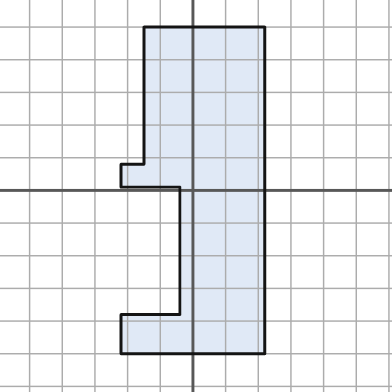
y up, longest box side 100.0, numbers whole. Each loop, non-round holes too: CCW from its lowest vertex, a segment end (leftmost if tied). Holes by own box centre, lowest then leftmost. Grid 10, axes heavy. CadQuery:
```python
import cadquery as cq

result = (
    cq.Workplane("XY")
    .moveTo(-22.0, -50.0)
    .lineTo(22.0, -50.0)
    .lineTo(22.0, 50.0)
    .lineTo(-15.0, 50.0)
    .lineTo(-15.0, 8.0)
    .lineTo(-22.0, 8.0)
    .lineTo(-22.0, 1.0)
    .lineTo(-4.0, 1.0)
    .lineTo(-4.0, -38.0)
    .lineTo(-22.0, -38.0)
    .close()
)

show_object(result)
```